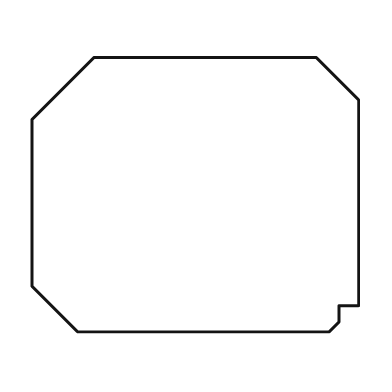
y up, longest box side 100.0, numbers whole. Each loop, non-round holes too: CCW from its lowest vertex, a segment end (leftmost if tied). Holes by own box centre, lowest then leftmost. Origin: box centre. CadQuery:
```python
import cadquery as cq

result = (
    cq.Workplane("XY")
    .moveTo(-36.0, -42.0)
    .lineTo(41.0, -42.0)
    .lineTo(44.0, -39.0)
    .lineTo(44.0, -34.0)
    .lineTo(50.0, -34.0)
    .lineTo(50.0, 29.0)
    .lineTo(37.0, 42.0)
    .lineTo(-31.0, 42.0)
    .lineTo(-50.0, 23.0)
    .lineTo(-50.0, -28.0)
    .close()
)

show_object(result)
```